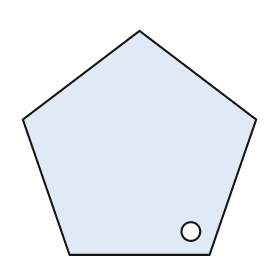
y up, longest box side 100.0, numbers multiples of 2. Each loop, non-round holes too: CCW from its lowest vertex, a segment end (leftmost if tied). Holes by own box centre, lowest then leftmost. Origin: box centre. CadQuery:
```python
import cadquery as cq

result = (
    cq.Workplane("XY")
    .moveTo(-30.0, -48.0)
    .lineTo(30.0, -48.0)
    .lineTo(50.0, 10.0)
    .lineTo(0.0, 48.0)
    .lineTo(-50.0, 10.0)
    .close()
    .moveTo(22.0, -38.0)
    .circle(4.0)
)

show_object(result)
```